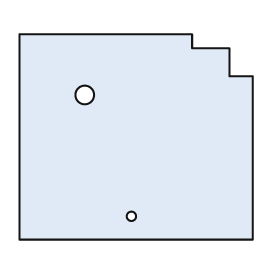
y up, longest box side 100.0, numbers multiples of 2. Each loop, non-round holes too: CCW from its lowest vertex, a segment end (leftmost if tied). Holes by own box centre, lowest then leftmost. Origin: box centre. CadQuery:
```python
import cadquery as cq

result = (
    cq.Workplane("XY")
    .moveTo(-50.0, -44.0)
    .lineTo(50.0, -44.0)
    .lineTo(50.0, 26.0)
    .lineTo(40.0, 26.0)
    .lineTo(40.0, 38.0)
    .lineTo(24.0, 38.0)
    .lineTo(24.0, 44.0)
    .lineTo(-50.0, 44.0)
    .close()
    .moveTo(-2.0, -34.0)
    .circle(2.0)
    .moveTo(-22.0, 18.0)
    .circle(4.0)
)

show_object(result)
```